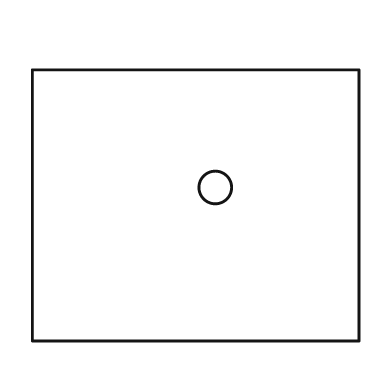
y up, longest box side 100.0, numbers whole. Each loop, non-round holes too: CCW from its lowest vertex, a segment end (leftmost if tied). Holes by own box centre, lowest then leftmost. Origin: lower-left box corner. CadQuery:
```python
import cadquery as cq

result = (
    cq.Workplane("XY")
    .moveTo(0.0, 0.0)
    .lineTo(100.0, 0.0)
    .lineTo(100.0, 83.0)
    .lineTo(0.0, 83.0)
    .close()
    .moveTo(56.0, 47.0)
    .circle(5.0)
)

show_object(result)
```